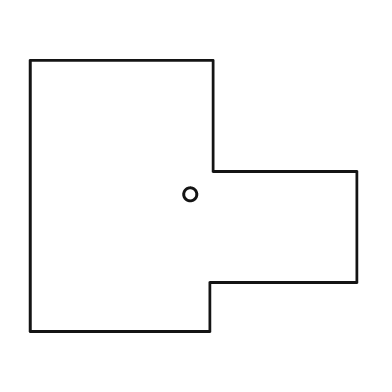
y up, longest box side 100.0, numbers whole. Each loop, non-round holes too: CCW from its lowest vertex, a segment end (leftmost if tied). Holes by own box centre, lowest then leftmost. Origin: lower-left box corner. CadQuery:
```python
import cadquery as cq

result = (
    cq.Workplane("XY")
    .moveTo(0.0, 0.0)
    .lineTo(55.0, 0.0)
    .lineTo(55.0, 15.0)
    .lineTo(100.0, 15.0)
    .lineTo(100.0, 49.0)
    .lineTo(56.0, 49.0)
    .lineTo(56.0, 83.0)
    .lineTo(0.0, 83.0)
    .close()
    .moveTo(49.0, 42.0)
    .circle(2.0)
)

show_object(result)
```